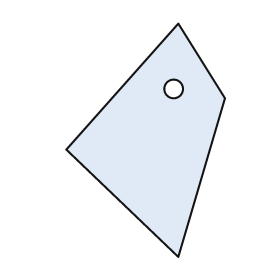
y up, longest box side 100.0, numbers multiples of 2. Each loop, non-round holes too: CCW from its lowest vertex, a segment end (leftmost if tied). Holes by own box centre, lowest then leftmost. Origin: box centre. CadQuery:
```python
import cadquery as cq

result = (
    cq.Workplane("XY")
    .moveTo(14.0, -50.0)
    .lineTo(34.0, 18.0)
    .lineTo(14.0, 50.0)
    .lineTo(-34.0, -4.0)
    .close()
    .moveTo(12.0, 22.0)
    .circle(4.0)
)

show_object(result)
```